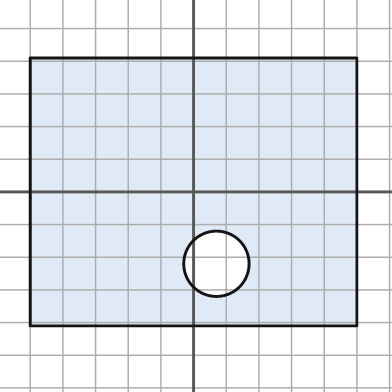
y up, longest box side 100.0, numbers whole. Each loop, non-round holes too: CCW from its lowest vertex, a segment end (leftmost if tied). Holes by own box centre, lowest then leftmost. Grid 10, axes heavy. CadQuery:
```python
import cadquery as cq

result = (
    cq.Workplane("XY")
    .moveTo(-50.0, -41.0)
    .lineTo(50.0, -41.0)
    .lineTo(50.0, 41.0)
    .lineTo(-50.0, 41.0)
    .close()
    .moveTo(7.0, -22.0)
    .circle(10.0)
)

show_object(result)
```